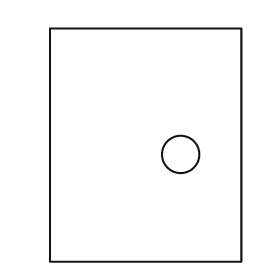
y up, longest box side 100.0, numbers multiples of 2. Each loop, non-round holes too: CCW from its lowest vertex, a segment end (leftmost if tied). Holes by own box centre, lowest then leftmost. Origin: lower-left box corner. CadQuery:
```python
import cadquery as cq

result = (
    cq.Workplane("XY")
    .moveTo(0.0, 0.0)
    .lineTo(82.0, 0.0)
    .lineTo(82.0, 100.0)
    .lineTo(0.0, 100.0)
    .close()
    .moveTo(56.0, 46.0)
    .circle(8.0)
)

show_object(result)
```